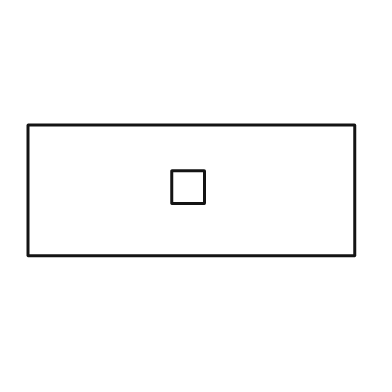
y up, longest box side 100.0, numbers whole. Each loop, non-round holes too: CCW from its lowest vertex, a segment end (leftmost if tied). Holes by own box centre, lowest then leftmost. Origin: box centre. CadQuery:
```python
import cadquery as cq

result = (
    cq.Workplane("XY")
    .moveTo(-50.0, -20.0)
    .lineTo(50.0, -20.0)
    .lineTo(50.0, 20.0)
    .lineTo(-50.0, 20.0)
    .close()
    .moveTo(-6.0, -4.0)
    .lineTo(4.0, -4.0)
    .lineTo(4.0, 6.0)
    .lineTo(-6.0, 6.0)
    .close()
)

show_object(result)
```